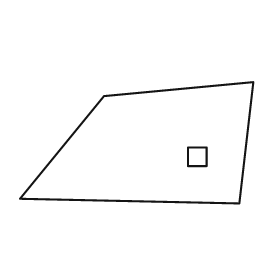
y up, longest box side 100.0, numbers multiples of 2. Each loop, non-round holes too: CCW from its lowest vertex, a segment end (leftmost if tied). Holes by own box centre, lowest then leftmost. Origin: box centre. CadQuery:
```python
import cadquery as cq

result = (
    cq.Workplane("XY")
    .moveTo(44.0, -26.0)
    .lineTo(50.0, 26.0)
    .lineTo(-14.0, 20.0)
    .lineTo(-50.0, -24.0)
    .close()
    .moveTo(22.0, -10.0)
    .lineTo(30.0, -10.0)
    .lineTo(30.0, -2.0)
    .lineTo(22.0, -2.0)
    .close()
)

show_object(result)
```